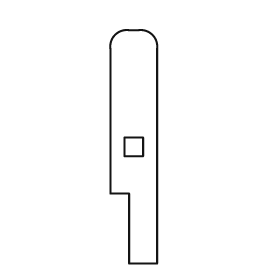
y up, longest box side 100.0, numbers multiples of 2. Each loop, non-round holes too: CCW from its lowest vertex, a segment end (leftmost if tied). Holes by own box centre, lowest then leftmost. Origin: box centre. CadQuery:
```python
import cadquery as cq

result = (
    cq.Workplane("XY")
    .moveTo(-2.0, -50.0)
    .lineTo(10.0, -50.0)
    .lineTo(10.0, 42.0)
    .threePointArc((8.0, 48.0), (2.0, 50.0))
    .lineTo(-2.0, 50.0)
    .threePointArc((-8.0, 48.0), (-10.0, 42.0))
    .lineTo(-10.0, -20.0)
    .lineTo(-2.0, -20.0)
    .close()
    .moveTo(-4.0, -4.0)
    .lineTo(4.0, -4.0)
    .lineTo(4.0, 4.0)
    .lineTo(-4.0, 4.0)
    .close()
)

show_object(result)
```